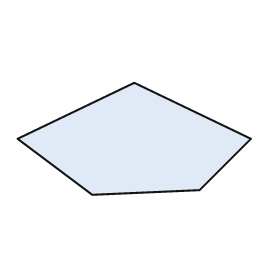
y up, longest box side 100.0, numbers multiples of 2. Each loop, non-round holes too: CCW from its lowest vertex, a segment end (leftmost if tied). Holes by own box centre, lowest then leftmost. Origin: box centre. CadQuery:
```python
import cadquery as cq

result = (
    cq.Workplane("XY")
    .moveTo(-18.0, -24.0)
    .lineTo(28.0, -22.0)
    .lineTo(50.0, 0.0)
    .lineTo(0.0, 24.0)
    .lineTo(-50.0, 0.0)
    .close()
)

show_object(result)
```